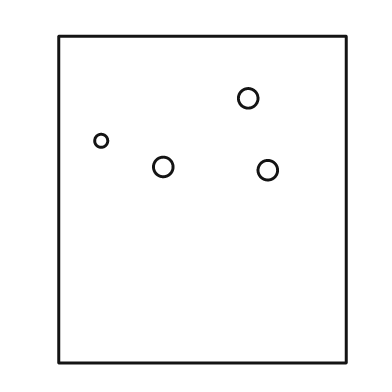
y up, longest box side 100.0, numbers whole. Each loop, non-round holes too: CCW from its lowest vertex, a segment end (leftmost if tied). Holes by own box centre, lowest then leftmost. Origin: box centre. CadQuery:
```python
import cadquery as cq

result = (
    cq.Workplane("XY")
    .moveTo(-44.0, -50.0)
    .lineTo(44.0, -50.0)
    .lineTo(44.0, 50.0)
    .lineTo(-44.0, 50.0)
    .close()
    .moveTo(20.0, 9.0)
    .circle(3.0)
    .moveTo(-12.0, 10.0)
    .circle(3.0)
    .moveTo(-31.0, 18.0)
    .circle(2.0)
    .moveTo(14.0, 31.0)
    .circle(3.0)
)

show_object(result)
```